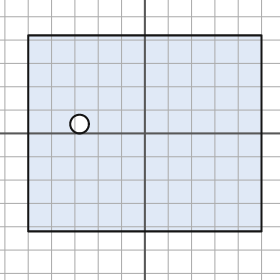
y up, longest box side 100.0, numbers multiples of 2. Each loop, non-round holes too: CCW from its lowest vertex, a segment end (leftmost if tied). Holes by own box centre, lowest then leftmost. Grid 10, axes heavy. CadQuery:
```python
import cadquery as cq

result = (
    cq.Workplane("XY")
    .moveTo(-50.0, -42.0)
    .lineTo(50.0, -42.0)
    .lineTo(50.0, 42.0)
    .lineTo(-50.0, 42.0)
    .close()
    .moveTo(-28.0, 4.0)
    .circle(4.0)
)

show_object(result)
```